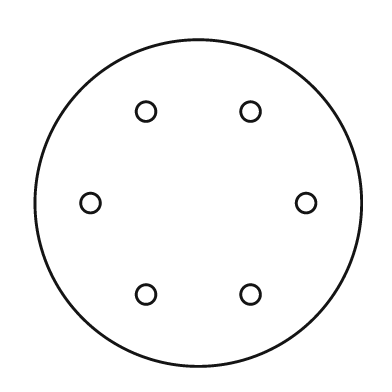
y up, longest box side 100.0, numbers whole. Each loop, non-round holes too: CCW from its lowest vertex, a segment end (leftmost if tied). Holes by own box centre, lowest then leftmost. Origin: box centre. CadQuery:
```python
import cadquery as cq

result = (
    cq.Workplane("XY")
    .moveTo(0.0, 0.0)
    .circle(50.0)
    .moveTo(-16.0, -28.0)
    .circle(3.0)
    .moveTo(16.0, -28.0)
    .circle(3.0)
    .moveTo(-33.0, 0.0)
    .circle(3.0)
    .moveTo(33.0, 0.0)
    .circle(3.0)
    .moveTo(-16.0, 28.0)
    .circle(3.0)
    .moveTo(16.0, 28.0)
    .circle(3.0)
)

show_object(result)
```